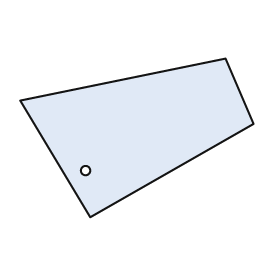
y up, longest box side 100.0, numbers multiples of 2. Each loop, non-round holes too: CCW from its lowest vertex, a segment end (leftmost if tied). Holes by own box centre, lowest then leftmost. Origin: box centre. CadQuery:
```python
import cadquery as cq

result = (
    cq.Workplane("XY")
    .moveTo(-20.0, -34.0)
    .lineTo(50.0, 6.0)
    .lineTo(38.0, 34.0)
    .lineTo(-50.0, 16.0)
    .close()
    .moveTo(-22.0, -14.0)
    .circle(2.0)
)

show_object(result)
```